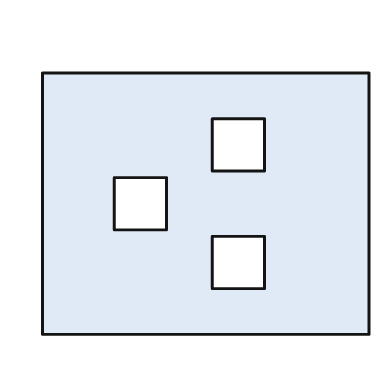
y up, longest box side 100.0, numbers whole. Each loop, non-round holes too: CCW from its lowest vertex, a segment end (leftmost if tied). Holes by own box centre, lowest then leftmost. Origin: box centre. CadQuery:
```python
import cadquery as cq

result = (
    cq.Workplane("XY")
    .moveTo(-50.0, -40.0)
    .lineTo(50.0, -40.0)
    .lineTo(50.0, 40.0)
    .lineTo(-50.0, 40.0)
    .close()
    .moveTo(2.0, -26.0)
    .lineTo(18.0, -26.0)
    .lineTo(18.0, -10.0)
    .lineTo(2.0, -10.0)
    .close()
    .moveTo(-28.0, -8.0)
    .lineTo(-12.0, -8.0)
    .lineTo(-12.0, 8.0)
    .lineTo(-28.0, 8.0)
    .close()
    .moveTo(2.0, 10.0)
    .lineTo(18.0, 10.0)
    .lineTo(18.0, 26.0)
    .lineTo(2.0, 26.0)
    .close()
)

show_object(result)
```